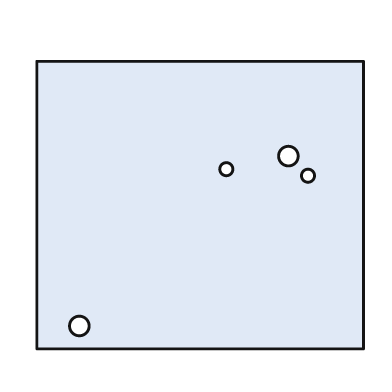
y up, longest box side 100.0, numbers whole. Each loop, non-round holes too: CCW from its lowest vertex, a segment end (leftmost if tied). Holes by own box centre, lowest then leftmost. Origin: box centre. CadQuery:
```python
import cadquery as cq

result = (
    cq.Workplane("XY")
    .moveTo(-50.0, -44.0)
    .lineTo(50.0, -44.0)
    .lineTo(50.0, 44.0)
    .lineTo(-50.0, 44.0)
    .close()
    .moveTo(-37.0, -37.0)
    .circle(3.0)
    .moveTo(33.0, 9.0)
    .circle(2.0)
    .moveTo(8.0, 11.0)
    .circle(2.0)
    .moveTo(27.0, 15.0)
    .circle(3.0)
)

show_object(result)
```